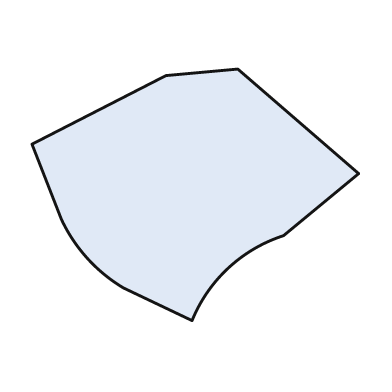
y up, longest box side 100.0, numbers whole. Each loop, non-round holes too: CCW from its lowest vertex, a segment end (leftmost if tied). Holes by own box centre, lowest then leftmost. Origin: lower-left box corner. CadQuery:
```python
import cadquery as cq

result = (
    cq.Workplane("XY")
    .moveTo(49.0, 0.0)
    .threePointArc((60.0, 16.0), (77.0, 26.0))
    .lineTo(100.0, 45.0)
    .lineTo(63.0, 77.0)
    .lineTo(41.0, 75.0)
    .lineTo(0.0, 54.0)
    .lineTo(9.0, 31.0)
    .threePointArc((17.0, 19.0), (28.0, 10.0))
    .close()
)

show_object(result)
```